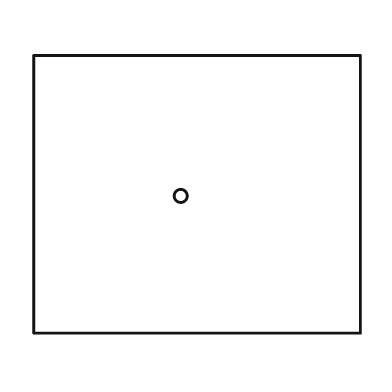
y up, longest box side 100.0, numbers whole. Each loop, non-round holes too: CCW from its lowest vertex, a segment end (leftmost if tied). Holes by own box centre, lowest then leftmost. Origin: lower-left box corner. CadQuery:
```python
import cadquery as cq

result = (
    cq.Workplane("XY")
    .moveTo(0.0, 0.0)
    .lineTo(100.0, 0.0)
    .lineTo(100.0, 85.0)
    .lineTo(0.0, 85.0)
    .close()
    .moveTo(45.0, 42.0)
    .circle(2.0)
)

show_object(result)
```